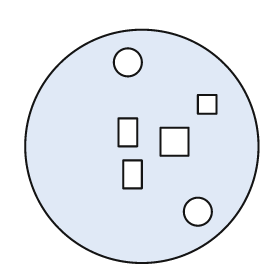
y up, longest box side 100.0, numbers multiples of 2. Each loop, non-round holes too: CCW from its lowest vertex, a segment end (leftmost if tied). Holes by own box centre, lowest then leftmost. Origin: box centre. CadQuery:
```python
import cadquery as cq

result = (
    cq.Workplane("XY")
    .moveTo(0.0, 0.0)
    .circle(50.0)
    .moveTo(24.0, -28.0)
    .circle(6.0)
    .moveTo(-8.0, -18.0)
    .lineTo(0.0, -18.0)
    .lineTo(0.0, -6.0)
    .lineTo(-8.0, -6.0)
    .close()
    .moveTo(8.0, -4.0)
    .lineTo(20.0, -4.0)
    .lineTo(20.0, 8.0)
    .lineTo(8.0, 8.0)
    .close()
    .moveTo(-10.0, 0.0)
    .lineTo(-2.0, 0.0)
    .lineTo(-2.0, 12.0)
    .lineTo(-10.0, 12.0)
    .close()
    .moveTo(24.0, 14.0)
    .lineTo(32.0, 14.0)
    .lineTo(32.0, 22.0)
    .lineTo(24.0, 22.0)
    .close()
    .moveTo(-6.0, 36.0)
    .circle(6.0)
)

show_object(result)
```